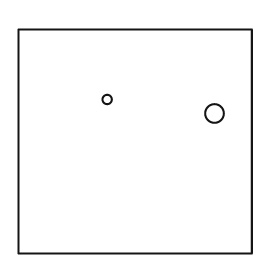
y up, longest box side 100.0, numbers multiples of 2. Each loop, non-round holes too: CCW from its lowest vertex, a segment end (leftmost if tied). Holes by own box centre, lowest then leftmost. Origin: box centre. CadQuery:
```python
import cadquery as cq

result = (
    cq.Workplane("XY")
    .moveTo(-50.0, -48.0)
    .lineTo(50.0, -48.0)
    .lineTo(50.0, 48.0)
    .lineTo(-50.0, 48.0)
    .close()
    .moveTo(34.0, 12.0)
    .circle(4.0)
    .moveTo(-12.0, 18.0)
    .circle(2.0)
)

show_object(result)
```